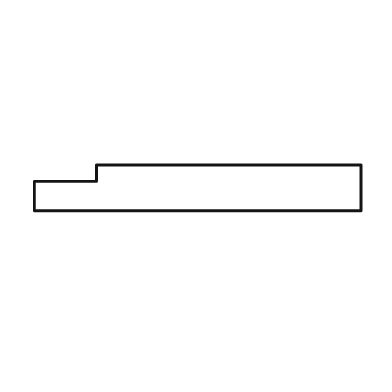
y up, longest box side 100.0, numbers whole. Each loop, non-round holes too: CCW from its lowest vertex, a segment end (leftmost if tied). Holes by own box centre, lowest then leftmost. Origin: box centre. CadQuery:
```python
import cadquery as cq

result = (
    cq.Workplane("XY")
    .moveTo(-50.0, -7.0)
    .lineTo(50.0, -7.0)
    .lineTo(50.0, 7.0)
    .lineTo(-31.0, 7.0)
    .lineTo(-31.0, 2.0)
    .lineTo(-50.0, 2.0)
    .close()
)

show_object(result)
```